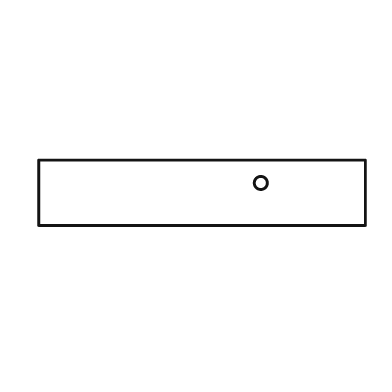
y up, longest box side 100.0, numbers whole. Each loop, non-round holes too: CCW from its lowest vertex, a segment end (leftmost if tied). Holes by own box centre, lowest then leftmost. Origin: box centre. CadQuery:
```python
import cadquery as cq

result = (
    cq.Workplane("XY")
    .moveTo(-50.0, -10.0)
    .lineTo(50.0, -10.0)
    .lineTo(50.0, 10.0)
    .lineTo(-50.0, 10.0)
    .close()
    .moveTo(18.0, 3.0)
    .circle(2.0)
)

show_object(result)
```